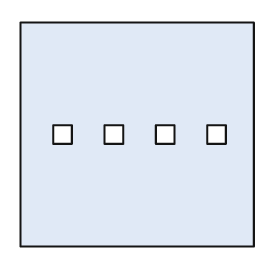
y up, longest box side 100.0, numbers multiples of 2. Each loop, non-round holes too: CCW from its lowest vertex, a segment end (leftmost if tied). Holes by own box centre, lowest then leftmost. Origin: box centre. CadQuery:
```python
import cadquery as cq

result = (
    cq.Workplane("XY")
    .moveTo(-50.0, -48.0)
    .lineTo(50.0, -48.0)
    .lineTo(50.0, 48.0)
    .lineTo(-50.0, 48.0)
    .close()
    .moveTo(-36.0, -4.0)
    .lineTo(-28.0, -4.0)
    .lineTo(-28.0, 4.0)
    .lineTo(-36.0, 4.0)
    .close()
    .moveTo(-14.0, -4.0)
    .lineTo(-6.0, -4.0)
    .lineTo(-6.0, 4.0)
    .lineTo(-14.0, 4.0)
    .close()
    .moveTo(8.0, -4.0)
    .lineTo(16.0, -4.0)
    .lineTo(16.0, 4.0)
    .lineTo(8.0, 4.0)
    .close()
    .moveTo(30.0, -4.0)
    .lineTo(38.0, -4.0)
    .lineTo(38.0, 4.0)
    .lineTo(30.0, 4.0)
    .close()
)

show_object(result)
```